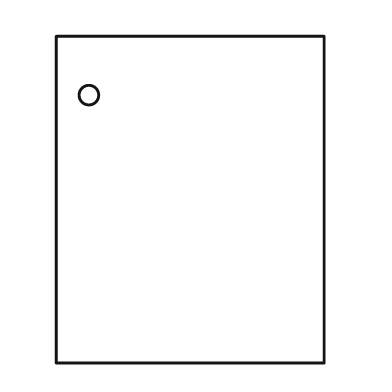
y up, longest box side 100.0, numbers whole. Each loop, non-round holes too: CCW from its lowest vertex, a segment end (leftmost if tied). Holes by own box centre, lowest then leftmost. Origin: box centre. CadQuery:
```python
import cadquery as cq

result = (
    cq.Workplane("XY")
    .moveTo(-41.0, -50.0)
    .lineTo(41.0, -50.0)
    .lineTo(41.0, 50.0)
    .lineTo(-41.0, 50.0)
    .close()
    .moveTo(-31.0, 32.0)
    .circle(3.0)
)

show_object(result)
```